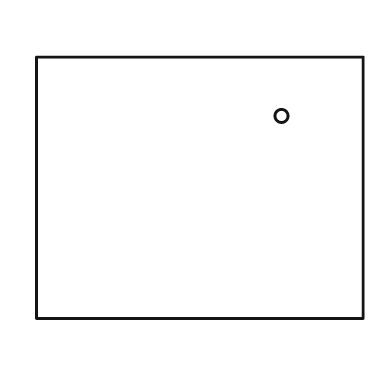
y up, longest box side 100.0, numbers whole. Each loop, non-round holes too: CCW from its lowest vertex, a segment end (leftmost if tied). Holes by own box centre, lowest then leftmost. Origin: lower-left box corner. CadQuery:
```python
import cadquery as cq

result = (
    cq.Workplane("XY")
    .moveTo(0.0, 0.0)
    .lineTo(100.0, 0.0)
    .lineTo(100.0, 80.0)
    .lineTo(0.0, 80.0)
    .close()
    .moveTo(75.0, 62.0)
    .circle(2.0)
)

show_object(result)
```